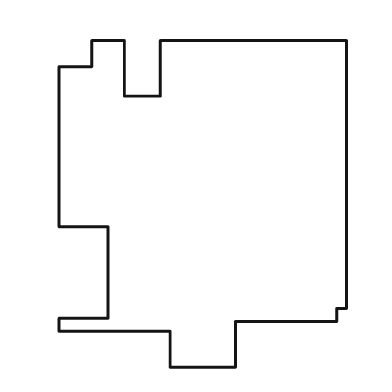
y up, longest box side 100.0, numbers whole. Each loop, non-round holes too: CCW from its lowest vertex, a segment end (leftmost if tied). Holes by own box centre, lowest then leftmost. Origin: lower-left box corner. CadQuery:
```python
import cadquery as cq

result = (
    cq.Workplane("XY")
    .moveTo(34.0, 0.0)
    .lineTo(54.0, 0.0)
    .lineTo(54.0, 14.0)
    .lineTo(85.0, 14.0)
    .lineTo(85.0, 18.0)
    .lineTo(88.0, 18.0)
    .lineTo(88.0, 100.0)
    .lineTo(31.0, 100.0)
    .lineTo(31.0, 83.0)
    .lineTo(20.0, 83.0)
    .lineTo(20.0, 100.0)
    .lineTo(10.0, 100.0)
    .lineTo(10.0, 92.0)
    .lineTo(0.0, 92.0)
    .lineTo(0.0, 43.0)
    .lineTo(15.0, 43.0)
    .lineTo(15.0, 15.0)
    .lineTo(0.0, 15.0)
    .lineTo(0.0, 11.0)
    .lineTo(34.0, 11.0)
    .close()
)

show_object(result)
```